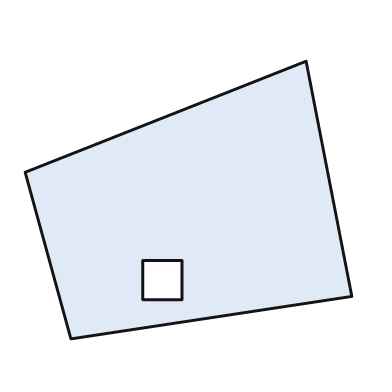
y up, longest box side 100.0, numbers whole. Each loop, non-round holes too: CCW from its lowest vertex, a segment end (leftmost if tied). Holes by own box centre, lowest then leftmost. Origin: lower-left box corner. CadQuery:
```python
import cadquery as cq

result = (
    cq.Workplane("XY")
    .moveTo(14.0, 0.0)
    .lineTo(100.0, 13.0)
    .lineTo(86.0, 85.0)
    .lineTo(0.0, 51.0)
    .close()
    .moveTo(36.0, 12.0)
    .lineTo(48.0, 12.0)
    .lineTo(48.0, 24.0)
    .lineTo(36.0, 24.0)
    .close()
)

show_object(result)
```